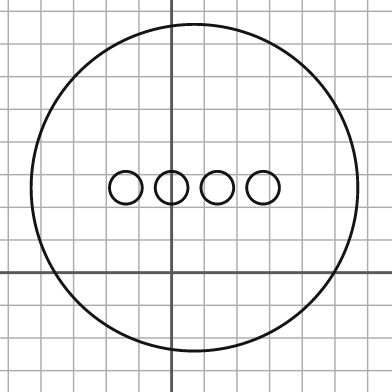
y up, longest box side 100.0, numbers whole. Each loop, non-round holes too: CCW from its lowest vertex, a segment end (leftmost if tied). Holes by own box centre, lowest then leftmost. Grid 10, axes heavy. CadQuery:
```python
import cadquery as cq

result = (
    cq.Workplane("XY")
    .moveTo(7.0, 26.0)
    .circle(50.0)
    .moveTo(-14.0, 26.0)
    .circle(5.0)
    .moveTo(0.0, 26.0)
    .circle(5.0)
    .moveTo(14.0, 26.0)
    .circle(5.0)
    .moveTo(28.0, 26.0)
    .circle(5.0)
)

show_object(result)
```